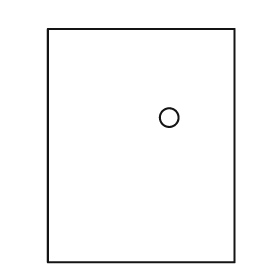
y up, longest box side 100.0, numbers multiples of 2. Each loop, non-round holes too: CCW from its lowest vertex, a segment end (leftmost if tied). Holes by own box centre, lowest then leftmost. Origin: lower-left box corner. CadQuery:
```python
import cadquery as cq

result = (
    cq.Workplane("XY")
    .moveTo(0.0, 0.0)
    .lineTo(80.0, 0.0)
    .lineTo(80.0, 100.0)
    .lineTo(0.0, 100.0)
    .close()
    .moveTo(52.0, 62.0)
    .circle(4.0)
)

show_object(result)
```